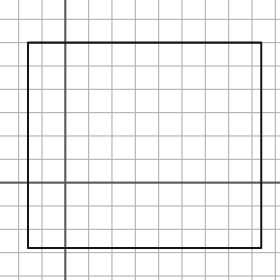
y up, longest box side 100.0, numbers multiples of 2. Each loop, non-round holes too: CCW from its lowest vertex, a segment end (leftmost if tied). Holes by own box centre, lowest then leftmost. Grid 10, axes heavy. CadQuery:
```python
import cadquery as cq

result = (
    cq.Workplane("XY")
    .moveTo(-16.0, -28.0)
    .lineTo(84.0, -28.0)
    .lineTo(84.0, 60.0)
    .lineTo(-16.0, 60.0)
    .close()
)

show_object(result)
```